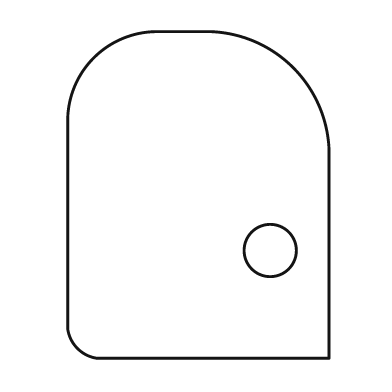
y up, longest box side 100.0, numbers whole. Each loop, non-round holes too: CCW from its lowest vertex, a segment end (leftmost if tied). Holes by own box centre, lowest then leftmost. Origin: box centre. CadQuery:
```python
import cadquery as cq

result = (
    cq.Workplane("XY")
    .moveTo(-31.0, -50.0)
    .lineTo(40.0, -50.0)
    .lineTo(40.0, 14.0)
    .threePointArc((29.0, 39.0), (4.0, 50.0))
    .lineTo(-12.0, 50.0)
    .threePointArc((-32.0, 42.0), (-40.0, 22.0))
    .lineTo(-40.0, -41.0)
    .threePointArc((-37.0, -47.0), (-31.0, -50.0))
    .close()
    .moveTo(22.0, -17.0)
    .circle(8.0)
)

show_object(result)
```